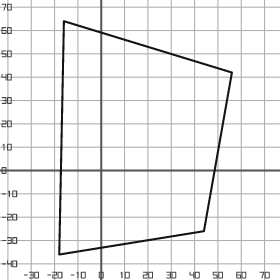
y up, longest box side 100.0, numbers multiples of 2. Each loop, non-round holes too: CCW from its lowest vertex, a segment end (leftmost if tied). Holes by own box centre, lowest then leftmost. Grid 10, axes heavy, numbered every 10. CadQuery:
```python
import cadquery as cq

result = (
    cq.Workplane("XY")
    .moveTo(-18.0, -36.0)
    .lineTo(44.0, -26.0)
    .lineTo(56.0, 42.0)
    .lineTo(-16.0, 64.0)
    .close()
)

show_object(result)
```